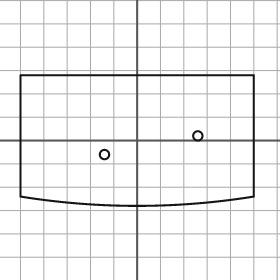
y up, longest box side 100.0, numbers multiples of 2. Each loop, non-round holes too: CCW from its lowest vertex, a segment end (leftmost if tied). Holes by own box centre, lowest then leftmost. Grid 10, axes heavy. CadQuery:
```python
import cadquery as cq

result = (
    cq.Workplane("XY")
    .moveTo(-50.0, -24.0)
    .threePointArc((0.0, -28.0), (50.0, -24.0))
    .lineTo(50.0, 28.0)
    .lineTo(-50.0, 28.0)
    .close()
    .moveTo(-14.0, -6.0)
    .circle(2.0)
    .moveTo(26.0, 2.0)
    .circle(2.0)
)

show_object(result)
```